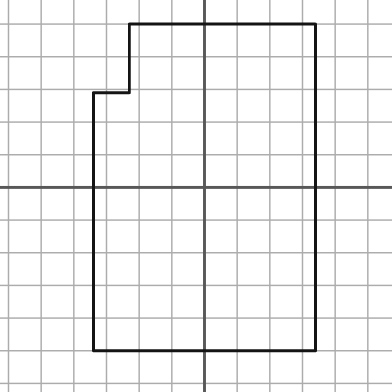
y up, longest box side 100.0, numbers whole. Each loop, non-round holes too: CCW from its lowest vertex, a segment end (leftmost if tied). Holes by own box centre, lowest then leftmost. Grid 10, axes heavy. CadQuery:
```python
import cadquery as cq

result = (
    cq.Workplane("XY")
    .moveTo(-34.0, -50.0)
    .lineTo(34.0, -50.0)
    .lineTo(34.0, 50.0)
    .lineTo(-23.0, 50.0)
    .lineTo(-23.0, 29.0)
    .lineTo(-34.0, 29.0)
    .close()
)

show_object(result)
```